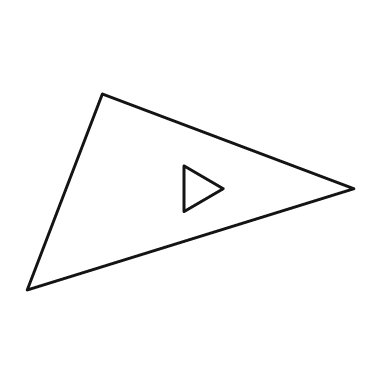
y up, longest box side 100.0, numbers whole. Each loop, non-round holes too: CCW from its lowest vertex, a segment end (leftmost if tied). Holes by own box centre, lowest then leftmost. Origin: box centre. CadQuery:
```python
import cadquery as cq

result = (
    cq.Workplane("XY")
    .moveTo(-50.0, -30.0)
    .lineTo(50.0, 1.0)
    .lineTo(-27.0, 30.0)
    .close()
    .moveTo(-2.0, -6.0)
    .lineTo(10.0, 1.0)
    .lineTo(-2.0, 8.0)
    .close()
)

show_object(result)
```